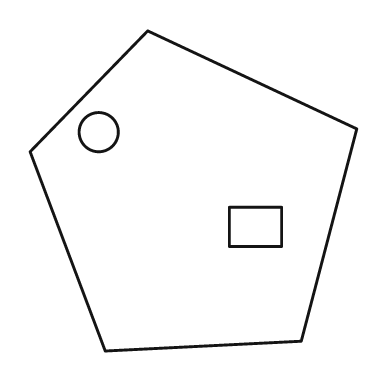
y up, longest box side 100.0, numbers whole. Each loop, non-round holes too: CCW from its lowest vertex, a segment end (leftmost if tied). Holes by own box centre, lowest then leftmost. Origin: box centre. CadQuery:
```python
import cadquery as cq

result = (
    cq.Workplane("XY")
    .moveTo(-27.0, -49.0)
    .lineTo(33.0, -46.0)
    .lineTo(50.0, 19.0)
    .lineTo(-14.0, 49.0)
    .lineTo(-50.0, 12.0)
    .close()
    .moveTo(11.0, -17.0)
    .lineTo(27.0, -17.0)
    .lineTo(27.0, -5.0)
    .lineTo(11.0, -5.0)
    .close()
    .moveTo(-29.0, 18.0)
    .circle(6.0)
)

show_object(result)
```